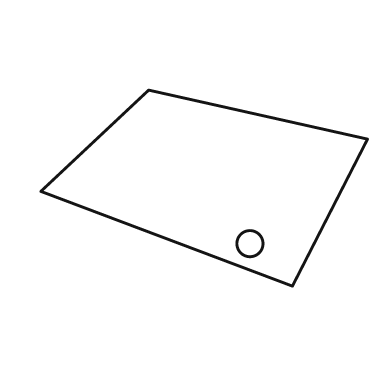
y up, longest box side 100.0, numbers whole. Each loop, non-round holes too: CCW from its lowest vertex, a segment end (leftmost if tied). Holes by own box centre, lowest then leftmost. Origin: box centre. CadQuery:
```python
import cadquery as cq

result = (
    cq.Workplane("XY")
    .moveTo(27.0, -30.0)
    .lineTo(50.0, 15.0)
    .lineTo(-17.0, 30.0)
    .lineTo(-50.0, -1.0)
    .close()
    .moveTo(14.0, -17.0)
    .circle(4.0)
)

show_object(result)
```